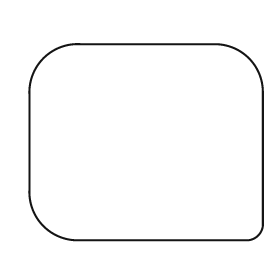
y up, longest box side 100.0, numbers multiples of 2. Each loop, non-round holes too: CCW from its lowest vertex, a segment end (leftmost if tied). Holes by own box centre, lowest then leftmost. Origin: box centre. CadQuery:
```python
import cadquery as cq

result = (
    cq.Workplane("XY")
    .moveTo(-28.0, -42.0)
    .lineTo(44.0, -42.0)
    .threePointArc((48.0, -40.0), (50.0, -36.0))
    .lineTo(50.0, 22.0)
    .threePointArc((44.0, 36.0), (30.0, 42.0))
    .lineTo(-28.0, 42.0)
    .threePointArc((-44.0, 36.0), (-50.0, 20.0))
    .lineTo(-50.0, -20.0)
    .threePointArc((-44.0, -36.0), (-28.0, -42.0))
    .close()
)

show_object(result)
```